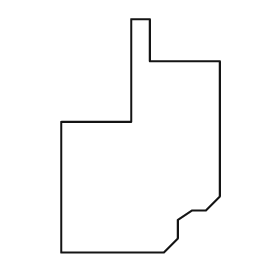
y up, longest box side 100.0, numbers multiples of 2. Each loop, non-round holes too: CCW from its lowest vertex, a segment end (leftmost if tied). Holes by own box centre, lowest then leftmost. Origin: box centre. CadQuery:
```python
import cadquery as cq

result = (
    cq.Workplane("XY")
    .moveTo(-34.0, -50.0)
    .lineTo(10.0, -50.0)
    .lineTo(16.0, -44.0)
    .lineTo(16.0, -36.0)
    .lineTo(22.0, -32.0)
    .lineTo(28.0, -32.0)
    .lineTo(34.0, -26.0)
    .lineTo(34.0, 32.0)
    .lineTo(4.0, 32.0)
    .lineTo(4.0, 50.0)
    .lineTo(-4.0, 50.0)
    .lineTo(-4.0, 6.0)
    .lineTo(-34.0, 6.0)
    .close()
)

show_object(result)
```